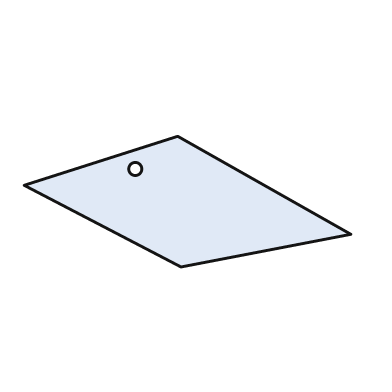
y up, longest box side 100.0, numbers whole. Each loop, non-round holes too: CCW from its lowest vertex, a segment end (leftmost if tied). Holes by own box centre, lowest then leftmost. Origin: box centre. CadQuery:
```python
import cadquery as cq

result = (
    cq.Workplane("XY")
    .moveTo(-2.0, -20.0)
    .lineTo(50.0, -10.0)
    .lineTo(-3.0, 20.0)
    .lineTo(-50.0, 5.0)
    .close()
    .moveTo(-16.0, 10.0)
    .circle(2.0)
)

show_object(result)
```